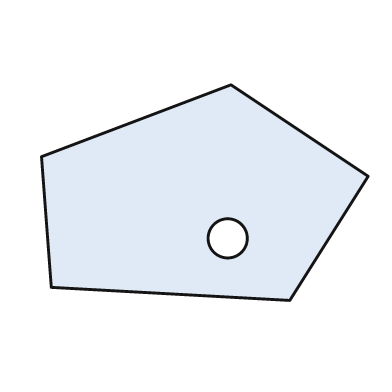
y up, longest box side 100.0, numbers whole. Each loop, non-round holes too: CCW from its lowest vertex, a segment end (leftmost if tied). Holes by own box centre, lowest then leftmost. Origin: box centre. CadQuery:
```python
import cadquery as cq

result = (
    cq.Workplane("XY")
    .moveTo(26.0, -33.0)
    .lineTo(50.0, 5.0)
    .lineTo(8.0, 33.0)
    .lineTo(-50.0, 11.0)
    .lineTo(-47.0, -29.0)
    .close()
    .moveTo(7.0, -14.0)
    .circle(6.0)
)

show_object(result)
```